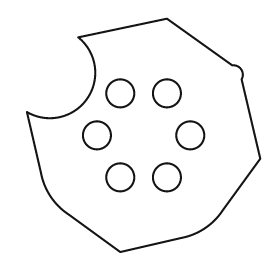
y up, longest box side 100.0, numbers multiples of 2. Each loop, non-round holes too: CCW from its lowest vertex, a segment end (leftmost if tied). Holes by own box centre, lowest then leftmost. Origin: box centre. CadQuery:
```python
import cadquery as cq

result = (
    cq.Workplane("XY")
    .moveTo(-10.0, -50.0)
    .lineTo(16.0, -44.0)
    .threePointArc((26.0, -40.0), (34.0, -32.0))
    .lineTo(50.0, -10.0)
    .lineTo(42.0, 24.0)
    .threePointArc((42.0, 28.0), (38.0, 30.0))
    .lineTo(10.0, 50.0)
    .lineTo(-28.0, 42.0)
    .threePointArc((-24.0, 16.0), (-50.0, 10.0))
    .lineTo(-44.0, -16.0)
    .threePointArc((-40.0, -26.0), (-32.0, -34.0))
    .close()
    .moveTo(-10.0, -18.0)
    .circle(6.0)
    .moveTo(10.0, -18.0)
    .circle(6.0)
    .moveTo(-20.0, 0.0)
    .circle(6.0)
    .moveTo(20.0, 0.0)
    .circle(6.0)
    .moveTo(-10.0, 18.0)
    .circle(6.0)
    .moveTo(10.0, 18.0)
    .circle(6.0)
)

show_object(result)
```